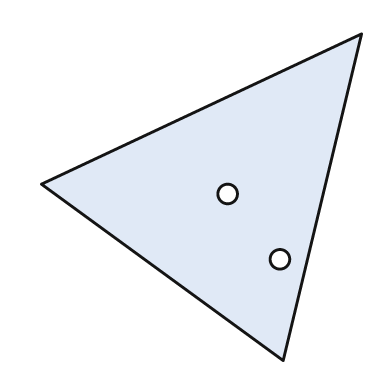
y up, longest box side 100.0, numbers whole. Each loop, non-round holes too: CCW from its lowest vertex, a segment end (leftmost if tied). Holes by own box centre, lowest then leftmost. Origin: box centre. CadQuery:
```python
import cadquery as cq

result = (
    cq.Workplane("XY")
    .moveTo(25.0, -50.0)
    .lineTo(49.0, 50.0)
    .lineTo(-49.0, 4.0)
    .close()
    .moveTo(24.0, -19.0)
    .circle(3.0)
    .moveTo(8.0, 1.0)
    .circle(3.0)
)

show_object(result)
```